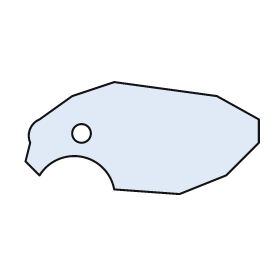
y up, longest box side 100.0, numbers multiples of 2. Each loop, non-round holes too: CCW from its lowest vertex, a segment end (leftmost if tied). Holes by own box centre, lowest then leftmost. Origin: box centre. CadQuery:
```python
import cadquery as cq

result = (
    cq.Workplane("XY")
    .moveTo(16.0, -24.0)
    .lineTo(36.0, -16.0)
    .lineTo(50.0, -2.0)
    .lineTo(50.0, 8.0)
    .lineTo(32.0, 18.0)
    .lineTo(-12.0, 24.0)
    .lineTo(-30.0, 18.0)
    .lineTo(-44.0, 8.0)
    .threePointArc((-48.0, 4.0), (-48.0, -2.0))
    .lineTo(-50.0, -10.0)
    .lineTo(-44.0, -16.0)
    .threePointArc((-26.0, -8.0), (-12.0, -22.0))
    .close()
    .moveTo(-26.0, 2.0)
    .circle(4.0)
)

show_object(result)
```